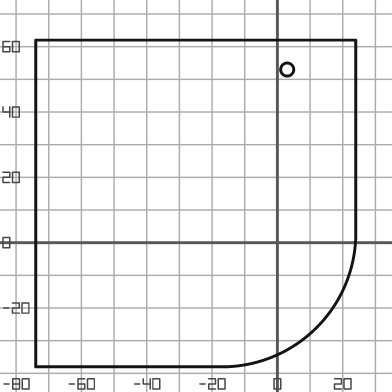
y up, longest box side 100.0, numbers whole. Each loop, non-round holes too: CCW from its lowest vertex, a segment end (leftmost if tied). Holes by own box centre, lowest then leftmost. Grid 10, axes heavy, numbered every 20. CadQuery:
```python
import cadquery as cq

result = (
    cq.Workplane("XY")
    .moveTo(-74.0, -38.0)
    .lineTo(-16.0, -38.0)
    .threePointArc((12.0, -26.0), (24.0, 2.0))
    .lineTo(24.0, 62.0)
    .lineTo(-74.0, 62.0)
    .close()
    .moveTo(3.0, 53.0)
    .circle(2.0)
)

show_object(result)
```